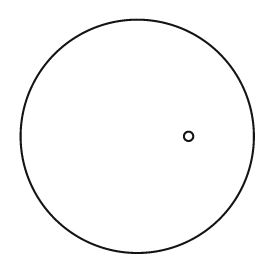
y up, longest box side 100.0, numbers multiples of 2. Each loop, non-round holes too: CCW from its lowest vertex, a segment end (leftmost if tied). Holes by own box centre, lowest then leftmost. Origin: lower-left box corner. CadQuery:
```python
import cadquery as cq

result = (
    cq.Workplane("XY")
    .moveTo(50.0, 50.0)
    .circle(50.0)
    .moveTo(72.0, 50.0)
    .circle(2.0)
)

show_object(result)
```